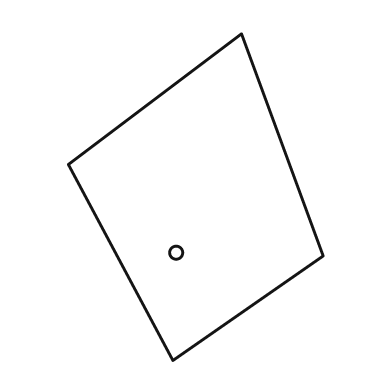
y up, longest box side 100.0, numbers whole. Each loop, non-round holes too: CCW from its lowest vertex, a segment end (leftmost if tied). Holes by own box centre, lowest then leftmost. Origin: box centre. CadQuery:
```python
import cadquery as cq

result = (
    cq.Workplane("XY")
    .moveTo(-7.0, -50.0)
    .lineTo(39.0, -18.0)
    .lineTo(14.0, 50.0)
    .lineTo(-39.0, 10.0)
    .close()
    .moveTo(-6.0, -17.0)
    .circle(2.0)
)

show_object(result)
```